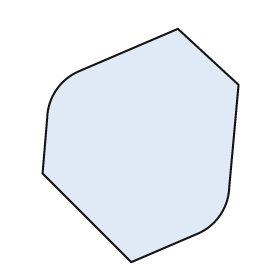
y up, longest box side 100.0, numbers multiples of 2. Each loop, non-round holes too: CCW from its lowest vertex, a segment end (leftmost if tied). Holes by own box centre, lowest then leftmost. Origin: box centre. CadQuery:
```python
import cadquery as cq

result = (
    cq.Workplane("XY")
    .moveTo(-4.0, -50.0)
    .lineTo(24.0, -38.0)
    .threePointArc((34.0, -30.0), (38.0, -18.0))
    .lineTo(42.0, 26.0)
    .lineTo(16.0, 50.0)
    .lineTo(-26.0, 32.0)
    .threePointArc((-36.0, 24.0), (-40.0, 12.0))
    .lineTo(-42.0, -12.0)
    .close()
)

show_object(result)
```